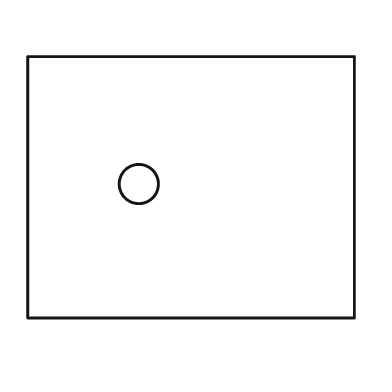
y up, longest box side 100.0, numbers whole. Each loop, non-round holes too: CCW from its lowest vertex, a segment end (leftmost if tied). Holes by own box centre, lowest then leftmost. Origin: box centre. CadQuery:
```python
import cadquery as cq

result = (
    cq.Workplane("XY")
    .moveTo(-50.0, -40.0)
    .lineTo(50.0, -40.0)
    .lineTo(50.0, 40.0)
    .lineTo(-50.0, 40.0)
    .close()
    .moveTo(-16.0, 1.0)
    .circle(6.0)
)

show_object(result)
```